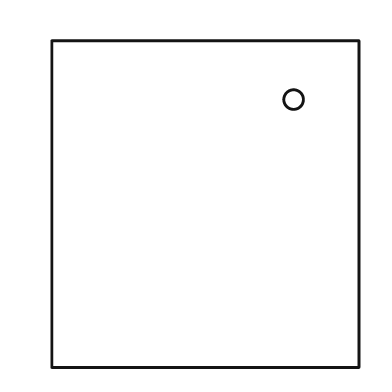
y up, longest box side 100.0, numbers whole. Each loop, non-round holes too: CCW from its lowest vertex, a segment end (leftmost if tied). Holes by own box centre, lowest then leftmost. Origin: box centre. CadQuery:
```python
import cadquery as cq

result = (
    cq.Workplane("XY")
    .moveTo(-47.0, -50.0)
    .lineTo(47.0, -50.0)
    .lineTo(47.0, 50.0)
    .lineTo(-47.0, 50.0)
    .close()
    .moveTo(27.0, 32.0)
    .circle(3.0)
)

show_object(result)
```